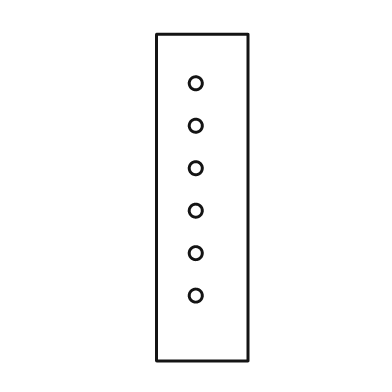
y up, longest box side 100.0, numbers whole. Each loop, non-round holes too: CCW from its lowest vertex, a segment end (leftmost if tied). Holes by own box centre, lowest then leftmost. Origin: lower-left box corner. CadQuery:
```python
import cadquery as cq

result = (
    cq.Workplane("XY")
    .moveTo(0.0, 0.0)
    .lineTo(28.0, 0.0)
    .lineTo(28.0, 100.0)
    .lineTo(0.0, 100.0)
    .close()
    .moveTo(12.0, 20.0)
    .circle(2.0)
    .moveTo(12.0, 33.0)
    .circle(2.0)
    .moveTo(12.0, 46.0)
    .circle(2.0)
    .moveTo(12.0, 59.0)
    .circle(2.0)
    .moveTo(12.0, 72.0)
    .circle(2.0)
    .moveTo(12.0, 85.0)
    .circle(2.0)
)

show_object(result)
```